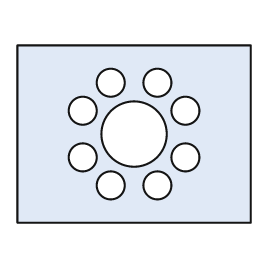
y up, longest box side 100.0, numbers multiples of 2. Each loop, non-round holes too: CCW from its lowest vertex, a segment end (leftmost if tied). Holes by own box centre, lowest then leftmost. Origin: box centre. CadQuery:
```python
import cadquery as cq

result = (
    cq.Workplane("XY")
    .moveTo(-50.0, -38.0)
    .lineTo(50.0, -38.0)
    .lineTo(50.0, 38.0)
    .lineTo(-50.0, 38.0)
    .close()
    .moveTo(-10.0, -22.0)
    .circle(6.0)
    .moveTo(10.0, -22.0)
    .circle(6.0)
    .moveTo(-22.0, -10.0)
    .circle(6.0)
    .moveTo(22.0, -10.0)
    .circle(6.0)
    .moveTo(0.0, 0.0)
    .circle(14.0)
    .moveTo(-22.0, 10.0)
    .circle(6.0)
    .moveTo(22.0, 10.0)
    .circle(6.0)
    .moveTo(-10.0, 22.0)
    .circle(6.0)
    .moveTo(10.0, 22.0)
    .circle(6.0)
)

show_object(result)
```